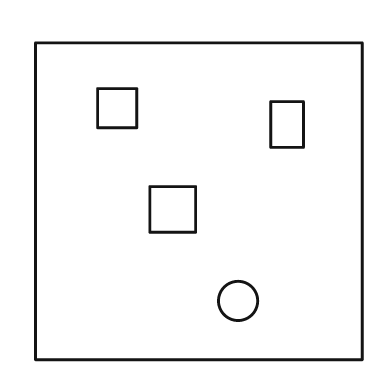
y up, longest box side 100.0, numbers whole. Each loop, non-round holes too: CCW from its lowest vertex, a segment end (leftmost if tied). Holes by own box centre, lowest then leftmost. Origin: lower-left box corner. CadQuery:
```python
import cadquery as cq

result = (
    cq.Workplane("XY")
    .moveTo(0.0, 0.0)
    .lineTo(100.0, 0.0)
    .lineTo(100.0, 97.0)
    .lineTo(0.0, 97.0)
    .close()
    .moveTo(62.0, 18.0)
    .circle(6.0)
    .moveTo(35.0, 39.0)
    .lineTo(49.0, 39.0)
    .lineTo(49.0, 53.0)
    .lineTo(35.0, 53.0)
    .close()
    .moveTo(72.0, 65.0)
    .lineTo(82.0, 65.0)
    .lineTo(82.0, 79.0)
    .lineTo(72.0, 79.0)
    .close()
    .moveTo(19.0, 71.0)
    .lineTo(31.0, 71.0)
    .lineTo(31.0, 83.0)
    .lineTo(19.0, 83.0)
    .close()
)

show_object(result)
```